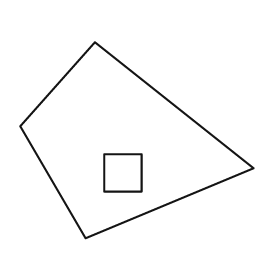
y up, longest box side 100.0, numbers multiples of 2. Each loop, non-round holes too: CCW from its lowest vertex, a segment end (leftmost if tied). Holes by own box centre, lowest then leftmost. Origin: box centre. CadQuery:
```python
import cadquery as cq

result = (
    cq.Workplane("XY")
    .moveTo(-22.0, -42.0)
    .lineTo(50.0, -12.0)
    .lineTo(-18.0, 42.0)
    .lineTo(-50.0, 6.0)
    .close()
    .moveTo(-14.0, -22.0)
    .lineTo(2.0, -22.0)
    .lineTo(2.0, -6.0)
    .lineTo(-14.0, -6.0)
    .close()
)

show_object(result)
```